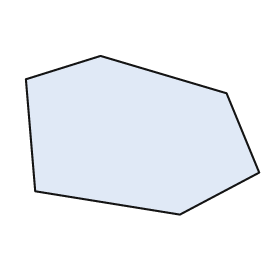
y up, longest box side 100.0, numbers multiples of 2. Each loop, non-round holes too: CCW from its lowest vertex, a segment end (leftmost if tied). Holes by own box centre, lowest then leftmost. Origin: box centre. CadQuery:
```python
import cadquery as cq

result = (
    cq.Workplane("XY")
    .moveTo(16.0, -34.0)
    .lineTo(50.0, -16.0)
    .lineTo(36.0, 18.0)
    .lineTo(-18.0, 34.0)
    .lineTo(-50.0, 24.0)
    .lineTo(-46.0, -24.0)
    .close()
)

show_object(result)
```